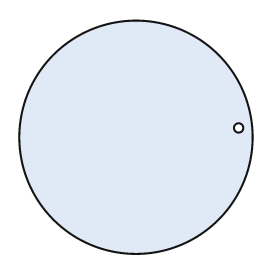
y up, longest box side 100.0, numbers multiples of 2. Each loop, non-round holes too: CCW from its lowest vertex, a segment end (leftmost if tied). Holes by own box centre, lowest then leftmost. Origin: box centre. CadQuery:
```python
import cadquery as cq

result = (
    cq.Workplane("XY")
    .moveTo(0.0, 0.0)
    .circle(50.0)
    .moveTo(44.0, 4.0)
    .circle(2.0)
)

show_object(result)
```